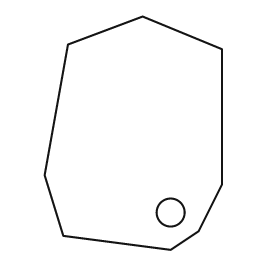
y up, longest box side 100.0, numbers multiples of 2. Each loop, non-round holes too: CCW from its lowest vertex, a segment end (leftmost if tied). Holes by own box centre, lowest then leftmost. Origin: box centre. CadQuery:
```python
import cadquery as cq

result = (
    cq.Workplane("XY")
    .moveTo(16.0, -50.0)
    .lineTo(28.0, -42.0)
    .lineTo(38.0, -22.0)
    .lineTo(38.0, 36.0)
    .lineTo(4.0, 50.0)
    .lineTo(-28.0, 38.0)
    .lineTo(-38.0, -18.0)
    .lineTo(-30.0, -44.0)
    .close()
    .moveTo(16.0, -34.0)
    .circle(6.0)
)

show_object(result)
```